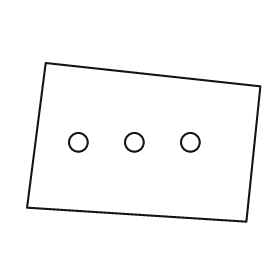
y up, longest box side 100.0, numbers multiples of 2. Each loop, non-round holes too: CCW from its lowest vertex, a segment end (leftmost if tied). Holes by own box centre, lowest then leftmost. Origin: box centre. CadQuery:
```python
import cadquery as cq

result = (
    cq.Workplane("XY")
    .moveTo(44.0, -34.0)
    .lineTo(50.0, 24.0)
    .lineTo(-42.0, 34.0)
    .lineTo(-50.0, -28.0)
    .close()
    .moveTo(-28.0, 0.0)
    .circle(4.0)
    .moveTo(-4.0, 0.0)
    .circle(4.0)
    .moveTo(20.0, 0.0)
    .circle(4.0)
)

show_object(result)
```